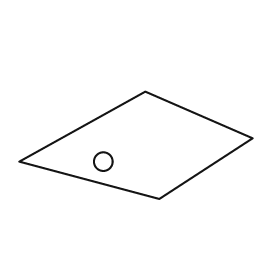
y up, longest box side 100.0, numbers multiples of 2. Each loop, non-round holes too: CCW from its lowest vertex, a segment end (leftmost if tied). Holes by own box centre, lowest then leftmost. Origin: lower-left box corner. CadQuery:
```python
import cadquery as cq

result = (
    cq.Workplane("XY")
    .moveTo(60.0, 0.0)
    .lineTo(100.0, 26.0)
    .lineTo(54.0, 46.0)
    .lineTo(0.0, 16.0)
    .close()
    .moveTo(36.0, 16.0)
    .circle(4.0)
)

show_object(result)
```